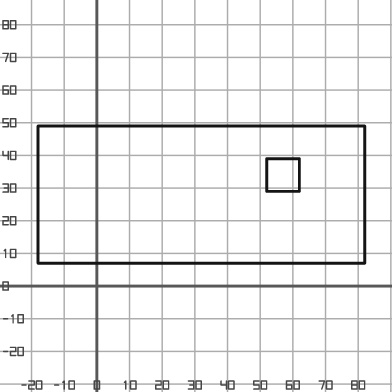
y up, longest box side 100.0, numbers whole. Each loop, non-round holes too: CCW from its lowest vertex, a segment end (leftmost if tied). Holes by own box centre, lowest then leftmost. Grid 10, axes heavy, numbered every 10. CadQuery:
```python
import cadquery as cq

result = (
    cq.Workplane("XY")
    .moveTo(-18.0, 7.0)
    .lineTo(82.0, 7.0)
    .lineTo(82.0, 49.0)
    .lineTo(-18.0, 49.0)
    .close()
    .moveTo(52.0, 29.0)
    .lineTo(62.0, 29.0)
    .lineTo(62.0, 39.0)
    .lineTo(52.0, 39.0)
    .close()
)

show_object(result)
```